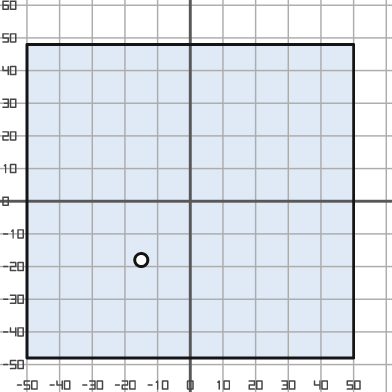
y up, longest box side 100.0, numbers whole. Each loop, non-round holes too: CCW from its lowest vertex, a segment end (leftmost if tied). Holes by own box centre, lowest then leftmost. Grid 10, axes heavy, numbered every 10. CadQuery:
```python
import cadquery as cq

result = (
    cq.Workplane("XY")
    .moveTo(-50.0, -48.0)
    .lineTo(50.0, -48.0)
    .lineTo(50.0, 48.0)
    .lineTo(-50.0, 48.0)
    .close()
    .moveTo(-15.0, -18.0)
    .circle(2.0)
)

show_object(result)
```